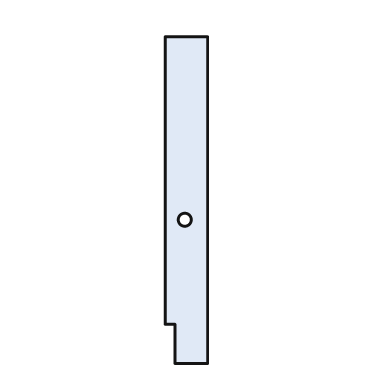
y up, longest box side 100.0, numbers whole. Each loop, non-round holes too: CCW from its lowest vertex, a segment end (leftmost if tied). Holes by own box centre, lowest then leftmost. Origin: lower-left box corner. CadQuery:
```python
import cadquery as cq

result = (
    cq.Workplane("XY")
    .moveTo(3.0, 0.0)
    .lineTo(13.0, 0.0)
    .lineTo(13.0, 100.0)
    .lineTo(0.0, 100.0)
    .lineTo(0.0, 12.0)
    .lineTo(3.0, 12.0)
    .close()
    .moveTo(6.0, 44.0)
    .circle(2.0)
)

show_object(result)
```